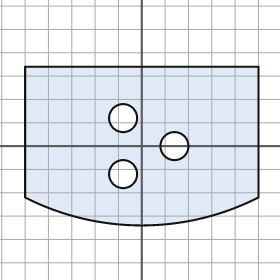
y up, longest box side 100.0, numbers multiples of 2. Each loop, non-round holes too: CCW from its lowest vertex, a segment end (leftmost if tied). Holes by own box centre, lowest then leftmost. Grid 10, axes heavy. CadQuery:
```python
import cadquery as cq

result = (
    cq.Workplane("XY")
    .moveTo(-50.0, -22.0)
    .threePointArc((0.0, -34.0), (50.0, -22.0))
    .lineTo(50.0, 34.0)
    .lineTo(-50.0, 34.0)
    .close()
    .moveTo(-8.0, -12.0)
    .circle(6.0)
    .moveTo(14.0, 0.0)
    .circle(6.0)
    .moveTo(-8.0, 12.0)
    .circle(6.0)
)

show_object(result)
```